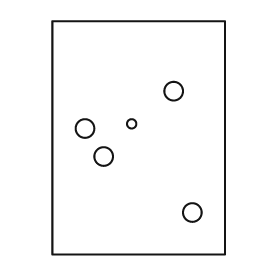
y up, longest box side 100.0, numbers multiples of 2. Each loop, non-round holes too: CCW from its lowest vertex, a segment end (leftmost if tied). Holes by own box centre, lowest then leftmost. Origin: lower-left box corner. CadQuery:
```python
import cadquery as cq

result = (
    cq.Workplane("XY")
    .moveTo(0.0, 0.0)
    .lineTo(74.0, 0.0)
    .lineTo(74.0, 100.0)
    .lineTo(0.0, 100.0)
    .close()
    .moveTo(60.0, 18.0)
    .circle(4.0)
    .moveTo(22.0, 42.0)
    .circle(4.0)
    .moveTo(14.0, 54.0)
    .circle(4.0)
    .moveTo(34.0, 56.0)
    .circle(2.0)
    .moveTo(52.0, 70.0)
    .circle(4.0)
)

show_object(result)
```